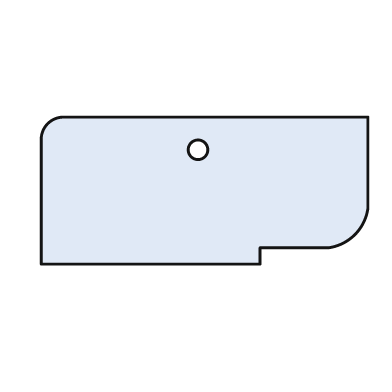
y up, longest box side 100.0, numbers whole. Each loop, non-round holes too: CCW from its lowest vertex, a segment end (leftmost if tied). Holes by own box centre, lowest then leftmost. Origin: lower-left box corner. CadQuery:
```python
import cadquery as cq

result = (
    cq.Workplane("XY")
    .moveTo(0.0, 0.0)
    .lineTo(67.0, 0.0)
    .lineTo(67.0, 5.0)
    .lineTo(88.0, 5.0)
    .threePointArc((96.0, 9.0), (100.0, 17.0))
    .lineTo(100.0, 45.0)
    .lineTo(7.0, 45.0)
    .threePointArc((2.0, 43.0), (0.0, 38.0))
    .close()
    .moveTo(48.0, 35.0)
    .circle(3.0)
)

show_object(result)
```